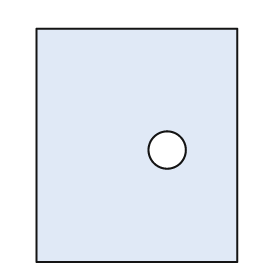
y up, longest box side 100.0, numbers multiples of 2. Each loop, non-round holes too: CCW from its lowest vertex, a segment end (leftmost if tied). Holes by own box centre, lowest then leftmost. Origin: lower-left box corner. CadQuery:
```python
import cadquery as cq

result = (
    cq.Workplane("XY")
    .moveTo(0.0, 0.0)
    .lineTo(86.0, 0.0)
    .lineTo(86.0, 100.0)
    .lineTo(0.0, 100.0)
    .close()
    .moveTo(56.0, 48.0)
    .circle(8.0)
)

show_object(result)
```